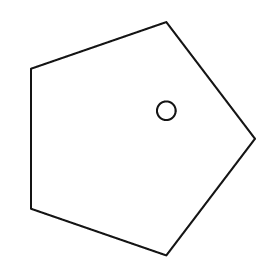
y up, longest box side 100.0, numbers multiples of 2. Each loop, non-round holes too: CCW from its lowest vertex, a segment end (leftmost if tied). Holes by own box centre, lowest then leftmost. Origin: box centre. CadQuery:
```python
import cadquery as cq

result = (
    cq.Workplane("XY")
    .moveTo(10.0, -50.0)
    .lineTo(48.0, 0.0)
    .lineTo(10.0, 50.0)
    .lineTo(-48.0, 30.0)
    .lineTo(-48.0, -30.0)
    .close()
    .moveTo(10.0, 12.0)
    .circle(4.0)
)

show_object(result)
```